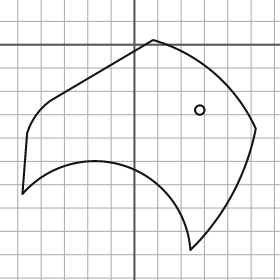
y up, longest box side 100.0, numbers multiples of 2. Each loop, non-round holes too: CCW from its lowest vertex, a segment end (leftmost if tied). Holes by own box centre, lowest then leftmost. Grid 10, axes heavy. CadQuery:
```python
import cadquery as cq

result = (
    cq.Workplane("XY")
    .moveTo(24.0, -88.0)
    .threePointArc((42.0, -64.0), (52.0, -36.0))
    .threePointArc((34.0, -12.0), (8.0, 2.0))
    .lineTo(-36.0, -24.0)
    .threePointArc((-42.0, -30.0), (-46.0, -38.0))
    .lineTo(-48.0, -64.0)
    .threePointArc((-4.0, -52.0), (24.0, -88.0))
    .close()
    .moveTo(28.0, -28.0)
    .circle(2.0)
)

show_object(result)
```